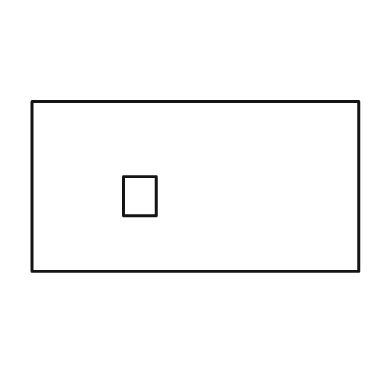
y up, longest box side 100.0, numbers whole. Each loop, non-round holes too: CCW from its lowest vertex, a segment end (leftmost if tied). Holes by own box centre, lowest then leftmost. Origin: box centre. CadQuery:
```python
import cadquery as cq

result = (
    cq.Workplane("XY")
    .moveTo(-50.0, -26.0)
    .lineTo(50.0, -26.0)
    .lineTo(50.0, 26.0)
    .lineTo(-50.0, 26.0)
    .close()
    .moveTo(-22.0, -9.0)
    .lineTo(-12.0, -9.0)
    .lineTo(-12.0, 3.0)
    .lineTo(-22.0, 3.0)
    .close()
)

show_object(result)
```